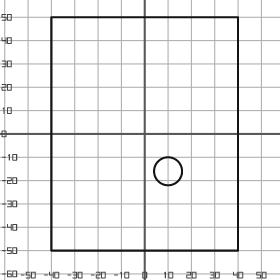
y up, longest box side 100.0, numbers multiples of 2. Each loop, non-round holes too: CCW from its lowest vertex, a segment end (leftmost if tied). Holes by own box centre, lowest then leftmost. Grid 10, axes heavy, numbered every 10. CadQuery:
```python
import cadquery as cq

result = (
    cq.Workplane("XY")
    .moveTo(-40.0, -50.0)
    .lineTo(40.0, -50.0)
    .lineTo(40.0, 50.0)
    .lineTo(-40.0, 50.0)
    .close()
    .moveTo(10.0, -16.0)
    .circle(6.0)
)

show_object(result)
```